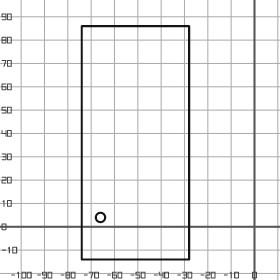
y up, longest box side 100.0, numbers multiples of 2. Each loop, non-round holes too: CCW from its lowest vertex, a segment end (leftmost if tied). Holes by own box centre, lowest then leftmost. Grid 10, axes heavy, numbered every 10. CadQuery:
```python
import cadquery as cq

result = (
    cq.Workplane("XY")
    .moveTo(-74.0, -14.0)
    .lineTo(-28.0, -14.0)
    .lineTo(-28.0, 86.0)
    .lineTo(-74.0, 86.0)
    .close()
    .moveTo(-66.0, 4.0)
    .circle(2.0)
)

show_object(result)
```